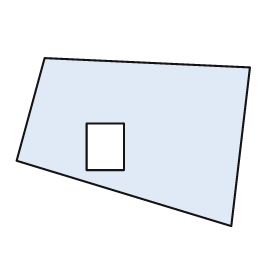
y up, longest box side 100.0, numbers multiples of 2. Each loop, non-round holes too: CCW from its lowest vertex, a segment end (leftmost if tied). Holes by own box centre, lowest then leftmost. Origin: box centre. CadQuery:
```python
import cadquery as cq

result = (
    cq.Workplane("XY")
    .moveTo(42.0, -36.0)
    .lineTo(50.0, 32.0)
    .lineTo(-38.0, 36.0)
    .lineTo(-50.0, -8.0)
    .close()
    .moveTo(-20.0, -12.0)
    .lineTo(-4.0, -12.0)
    .lineTo(-4.0, 8.0)
    .lineTo(-20.0, 8.0)
    .close()
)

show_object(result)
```